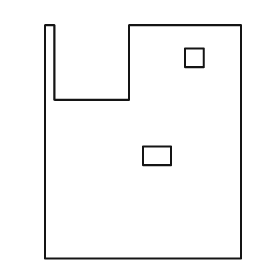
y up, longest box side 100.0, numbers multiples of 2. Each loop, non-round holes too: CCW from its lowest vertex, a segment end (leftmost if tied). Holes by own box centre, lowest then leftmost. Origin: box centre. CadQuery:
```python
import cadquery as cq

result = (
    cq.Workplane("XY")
    .moveTo(-42.0, -50.0)
    .lineTo(42.0, -50.0)
    .lineTo(42.0, 50.0)
    .lineTo(-6.0, 50.0)
    .lineTo(-6.0, 18.0)
    .lineTo(-38.0, 18.0)
    .lineTo(-38.0, 50.0)
    .lineTo(-42.0, 50.0)
    .close()
    .moveTo(0.0, -10.0)
    .lineTo(12.0, -10.0)
    .lineTo(12.0, -2.0)
    .lineTo(0.0, -2.0)
    .close()
    .moveTo(18.0, 32.0)
    .lineTo(26.0, 32.0)
    .lineTo(26.0, 40.0)
    .lineTo(18.0, 40.0)
    .close()
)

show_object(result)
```